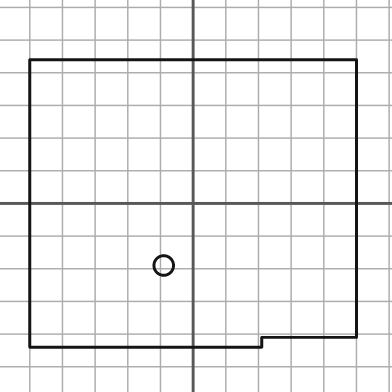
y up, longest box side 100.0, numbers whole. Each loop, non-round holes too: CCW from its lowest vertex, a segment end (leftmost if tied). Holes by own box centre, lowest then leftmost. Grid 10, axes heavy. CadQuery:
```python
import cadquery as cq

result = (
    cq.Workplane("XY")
    .moveTo(-50.0, -44.0)
    .lineTo(21.0, -44.0)
    .lineTo(21.0, -41.0)
    .lineTo(50.0, -41.0)
    .lineTo(50.0, 44.0)
    .lineTo(-50.0, 44.0)
    .close()
    .moveTo(-9.0, -19.0)
    .circle(3.0)
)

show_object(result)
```